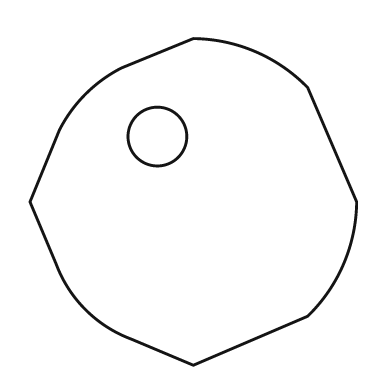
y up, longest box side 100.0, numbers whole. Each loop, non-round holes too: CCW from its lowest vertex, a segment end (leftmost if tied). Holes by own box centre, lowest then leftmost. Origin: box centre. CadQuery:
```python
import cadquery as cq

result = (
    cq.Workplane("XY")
    .moveTo(0.0, -50.0)
    .lineTo(35.0, -35.0)
    .threePointArc((46.0, -19.0), (50.0, 0.0))
    .lineTo(35.0, 35.0)
    .threePointArc((19.0, 46.0), (0.0, 50.0))
    .lineTo(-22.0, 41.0)
    .threePointArc((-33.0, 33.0), (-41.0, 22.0))
    .lineTo(-50.0, 0.0)
    .lineTo(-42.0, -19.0)
    .threePointArc((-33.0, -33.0), (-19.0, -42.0))
    .close()
    .moveTo(-11.0, 20.0)
    .circle(9.0)
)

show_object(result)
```